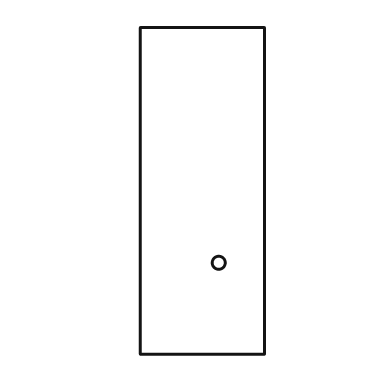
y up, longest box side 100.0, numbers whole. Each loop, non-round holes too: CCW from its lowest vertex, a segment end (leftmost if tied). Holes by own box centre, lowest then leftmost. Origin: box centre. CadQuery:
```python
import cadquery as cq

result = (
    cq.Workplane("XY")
    .moveTo(-19.0, -50.0)
    .lineTo(19.0, -50.0)
    .lineTo(19.0, 50.0)
    .lineTo(-19.0, 50.0)
    .close()
    .moveTo(5.0, -22.0)
    .circle(2.0)
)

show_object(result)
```